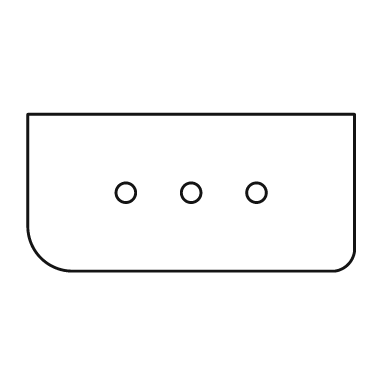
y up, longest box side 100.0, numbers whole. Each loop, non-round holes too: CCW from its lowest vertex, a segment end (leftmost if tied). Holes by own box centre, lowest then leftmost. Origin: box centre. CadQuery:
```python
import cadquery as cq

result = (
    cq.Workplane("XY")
    .moveTo(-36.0, -24.0)
    .lineTo(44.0, -24.0)
    .threePointArc((48.0, -22.0), (50.0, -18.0))
    .lineTo(50.0, 24.0)
    .lineTo(-50.0, 24.0)
    .lineTo(-50.0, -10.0)
    .threePointArc((-46.0, -20.0), (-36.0, -24.0))
    .close()
    .moveTo(-20.0, 0.0)
    .circle(3.0)
    .moveTo(0.0, 0.0)
    .circle(3.0)
    .moveTo(20.0, 0.0)
    .circle(3.0)
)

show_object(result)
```